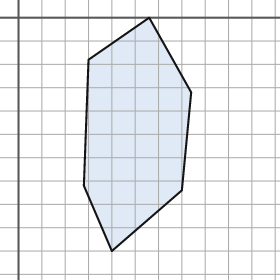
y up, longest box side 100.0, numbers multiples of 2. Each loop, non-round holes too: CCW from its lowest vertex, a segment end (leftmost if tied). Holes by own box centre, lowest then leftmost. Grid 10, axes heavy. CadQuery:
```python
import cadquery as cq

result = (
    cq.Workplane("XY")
    .moveTo(40.0, -100.0)
    .lineTo(70.0, -74.0)
    .lineTo(74.0, -32.0)
    .lineTo(56.0, 0.0)
    .lineTo(30.0, -18.0)
    .lineTo(28.0, -72.0)
    .close()
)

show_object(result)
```